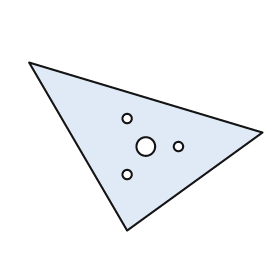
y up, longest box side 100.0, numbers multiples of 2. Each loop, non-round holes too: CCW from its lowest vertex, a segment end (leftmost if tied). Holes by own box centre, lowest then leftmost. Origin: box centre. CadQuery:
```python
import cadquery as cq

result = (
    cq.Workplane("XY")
    .moveTo(-8.0, -36.0)
    .lineTo(50.0, 6.0)
    .lineTo(-50.0, 36.0)
    .close()
    .moveTo(-8.0, -12.0)
    .circle(2.0)
    .moveTo(0.0, 0.0)
    .circle(4.0)
    .moveTo(14.0, 0.0)
    .circle(2.0)
    .moveTo(-8.0, 12.0)
    .circle(2.0)
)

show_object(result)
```